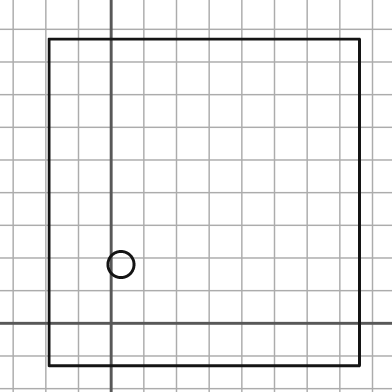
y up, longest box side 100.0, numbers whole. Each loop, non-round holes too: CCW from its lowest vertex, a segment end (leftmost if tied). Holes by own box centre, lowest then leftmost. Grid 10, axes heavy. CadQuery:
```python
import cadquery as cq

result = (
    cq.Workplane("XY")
    .moveTo(-19.0, -13.0)
    .lineTo(76.0, -13.0)
    .lineTo(76.0, 87.0)
    .lineTo(-19.0, 87.0)
    .close()
    .moveTo(3.0, 18.0)
    .circle(4.0)
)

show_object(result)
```